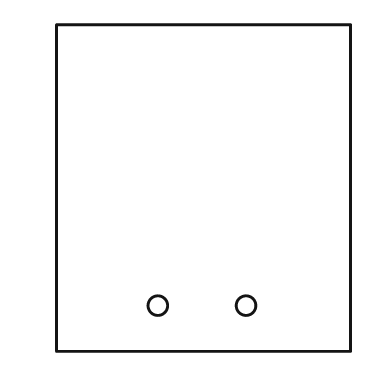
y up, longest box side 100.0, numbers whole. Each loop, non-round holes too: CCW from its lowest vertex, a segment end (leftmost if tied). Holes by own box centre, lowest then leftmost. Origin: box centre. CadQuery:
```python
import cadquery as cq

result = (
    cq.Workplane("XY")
    .moveTo(-45.0, -50.0)
    .lineTo(45.0, -50.0)
    .lineTo(45.0, 50.0)
    .lineTo(-45.0, 50.0)
    .close()
    .moveTo(-14.0, -36.0)
    .circle(3.0)
    .moveTo(13.0, -36.0)
    .circle(3.0)
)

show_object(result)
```